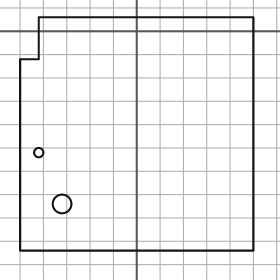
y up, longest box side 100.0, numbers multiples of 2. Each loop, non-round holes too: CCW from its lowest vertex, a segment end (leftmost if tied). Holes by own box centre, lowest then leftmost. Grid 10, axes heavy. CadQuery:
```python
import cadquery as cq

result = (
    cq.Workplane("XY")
    .moveTo(-50.0, -94.0)
    .lineTo(50.0, -94.0)
    .lineTo(50.0, 6.0)
    .lineTo(-42.0, 6.0)
    .lineTo(-42.0, -12.0)
    .lineTo(-50.0, -12.0)
    .close()
    .moveTo(-32.0, -74.0)
    .circle(4.0)
    .moveTo(-42.0, -52.0)
    .circle(2.0)
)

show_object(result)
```